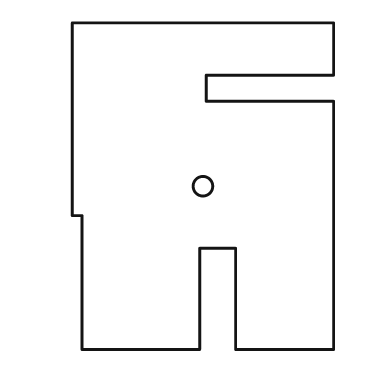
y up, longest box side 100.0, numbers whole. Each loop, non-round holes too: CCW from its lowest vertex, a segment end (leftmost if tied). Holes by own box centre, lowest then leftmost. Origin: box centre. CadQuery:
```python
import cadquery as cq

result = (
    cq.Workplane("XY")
    .moveTo(-37.0, -50.0)
    .lineTo(-1.0, -50.0)
    .lineTo(-1.0, -19.0)
    .lineTo(10.0, -19.0)
    .lineTo(10.0, -50.0)
    .lineTo(40.0, -50.0)
    .lineTo(40.0, 26.0)
    .lineTo(1.0, 26.0)
    .lineTo(1.0, 34.0)
    .lineTo(40.0, 34.0)
    .lineTo(40.0, 50.0)
    .lineTo(-40.0, 50.0)
    .lineTo(-40.0, -9.0)
    .lineTo(-37.0, -9.0)
    .close()
    .moveTo(0.0, 0.0)
    .circle(3.0)
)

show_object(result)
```